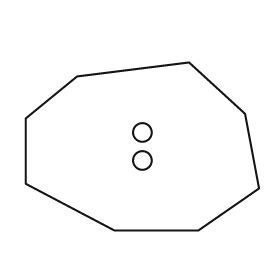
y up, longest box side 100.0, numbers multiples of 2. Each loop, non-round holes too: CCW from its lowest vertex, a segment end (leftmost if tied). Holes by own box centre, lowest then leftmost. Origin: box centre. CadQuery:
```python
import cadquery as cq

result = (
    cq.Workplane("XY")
    .moveTo(-12.0, -36.0)
    .lineTo(24.0, -36.0)
    .lineTo(50.0, -18.0)
    .lineTo(44.0, 14.0)
    .lineTo(20.0, 36.0)
    .lineTo(-28.0, 30.0)
    .lineTo(-50.0, 12.0)
    .lineTo(-50.0, -16.0)
    .close()
    .moveTo(0.0, -6.0)
    .circle(4.0)
    .moveTo(0.0, 6.0)
    .circle(4.0)
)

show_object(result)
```